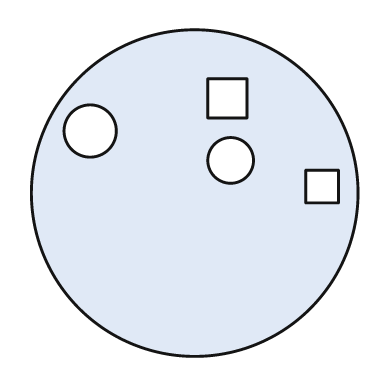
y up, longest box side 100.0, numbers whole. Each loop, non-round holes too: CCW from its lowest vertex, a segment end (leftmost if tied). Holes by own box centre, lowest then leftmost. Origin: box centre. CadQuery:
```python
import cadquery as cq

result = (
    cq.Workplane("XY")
    .moveTo(0.0, 0.0)
    .circle(50.0)
    .moveTo(34.0, -3.0)
    .lineTo(44.0, -3.0)
    .lineTo(44.0, 7.0)
    .lineTo(34.0, 7.0)
    .close()
    .moveTo(11.0, 10.0)
    .circle(7.0)
    .moveTo(-32.0, 19.0)
    .circle(8.0)
    .moveTo(4.0, 23.0)
    .lineTo(16.0, 23.0)
    .lineTo(16.0, 35.0)
    .lineTo(4.0, 35.0)
    .close()
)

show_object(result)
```